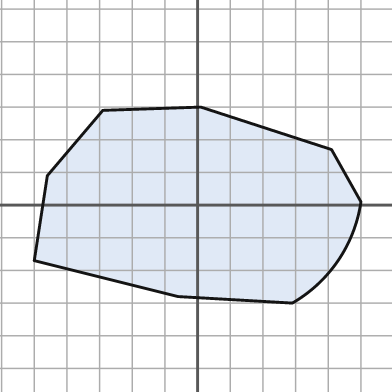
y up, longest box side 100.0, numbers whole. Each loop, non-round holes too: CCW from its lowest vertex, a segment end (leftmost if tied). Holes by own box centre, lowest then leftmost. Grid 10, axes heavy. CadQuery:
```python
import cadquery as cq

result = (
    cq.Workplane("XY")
    .moveTo(29.0, -30.0)
    .threePointArc((43.0, -17.0), (50.0, 1.0))
    .lineTo(41.0, 17.0)
    .lineTo(1.0, 30.0)
    .lineTo(-29.0, 29.0)
    .lineTo(-46.0, 9.0)
    .lineTo(-50.0, -17.0)
    .lineTo(-6.0, -28.0)
    .close()
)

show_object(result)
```